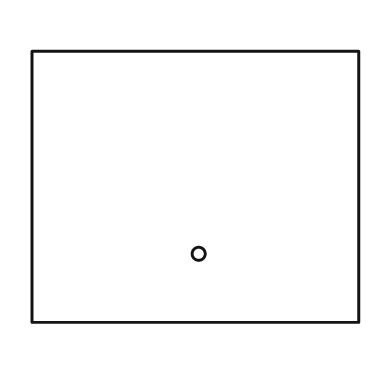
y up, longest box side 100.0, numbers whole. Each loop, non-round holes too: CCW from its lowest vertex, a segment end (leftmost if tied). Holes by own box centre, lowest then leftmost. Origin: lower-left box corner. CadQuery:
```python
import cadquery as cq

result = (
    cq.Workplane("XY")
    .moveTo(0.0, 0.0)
    .lineTo(100.0, 0.0)
    .lineTo(100.0, 83.0)
    .lineTo(0.0, 83.0)
    .close()
    .moveTo(51.0, 21.0)
    .circle(2.0)
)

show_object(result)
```